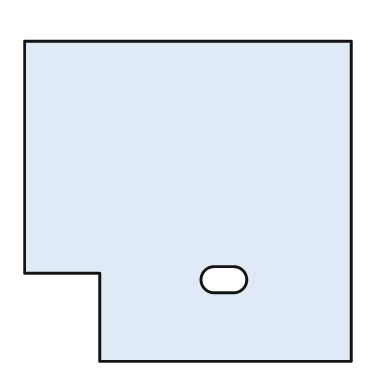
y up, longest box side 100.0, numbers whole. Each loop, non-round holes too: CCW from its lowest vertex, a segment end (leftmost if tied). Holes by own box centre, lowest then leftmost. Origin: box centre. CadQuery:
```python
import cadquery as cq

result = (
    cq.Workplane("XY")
    .moveTo(-27.0, -49.0)
    .lineTo(50.0, -49.0)
    .lineTo(50.0, 49.0)
    .lineTo(-50.0, 49.0)
    .lineTo(-50.0, -22.0)
    .lineTo(-27.0, -22.0)
    .close()
    .moveTo(8.0, -28.0)
    .lineTo(14.0, -28.0)
    .threePointArc((18.0, -24.0), (14.0, -20.0))
    .lineTo(8.0, -20.0)
    .threePointArc((4.0, -24.0), (8.0, -28.0))
    .close()
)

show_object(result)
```